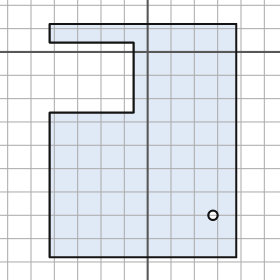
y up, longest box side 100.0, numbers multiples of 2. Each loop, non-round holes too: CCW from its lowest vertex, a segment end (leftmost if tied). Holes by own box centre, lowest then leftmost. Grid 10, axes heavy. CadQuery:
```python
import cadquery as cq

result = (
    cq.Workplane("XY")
    .moveTo(-42.0, -88.0)
    .lineTo(38.0, -88.0)
    .lineTo(38.0, 12.0)
    .lineTo(-42.0, 12.0)
    .lineTo(-42.0, 4.0)
    .lineTo(-6.0, 4.0)
    .lineTo(-6.0, -26.0)
    .lineTo(-42.0, -26.0)
    .close()
    .moveTo(28.0, -70.0)
    .circle(2.0)
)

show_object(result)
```